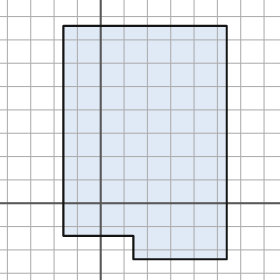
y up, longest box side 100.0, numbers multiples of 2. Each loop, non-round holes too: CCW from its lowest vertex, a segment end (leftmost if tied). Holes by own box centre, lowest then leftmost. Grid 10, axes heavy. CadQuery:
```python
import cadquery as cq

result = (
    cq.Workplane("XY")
    .moveTo(14.0, -24.0)
    .lineTo(54.0, -24.0)
    .lineTo(54.0, 76.0)
    .lineTo(-16.0, 76.0)
    .lineTo(-16.0, -14.0)
    .lineTo(14.0, -14.0)
    .close()
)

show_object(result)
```